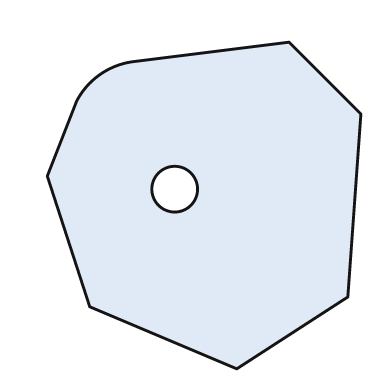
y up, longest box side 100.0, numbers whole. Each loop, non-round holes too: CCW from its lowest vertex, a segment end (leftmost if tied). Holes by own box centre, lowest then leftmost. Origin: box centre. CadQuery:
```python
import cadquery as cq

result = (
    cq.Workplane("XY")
    .moveTo(10.0, -50.0)
    .lineTo(44.0, -28.0)
    .lineTo(48.0, 28.0)
    .lineTo(26.0, 50.0)
    .lineTo(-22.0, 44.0)
    .threePointArc((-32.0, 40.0), (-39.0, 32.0))
    .lineTo(-48.0, 9.0)
    .lineTo(-35.0, -31.0)
    .close()
    .moveTo(-9.0, 5.0)
    .circle(7.0)
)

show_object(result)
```